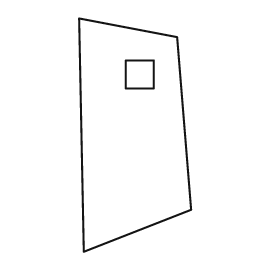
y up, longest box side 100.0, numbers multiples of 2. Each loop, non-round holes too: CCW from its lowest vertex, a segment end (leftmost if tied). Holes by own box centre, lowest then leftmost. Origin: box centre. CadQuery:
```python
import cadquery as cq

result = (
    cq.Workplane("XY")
    .moveTo(-22.0, -50.0)
    .lineTo(24.0, -32.0)
    .lineTo(18.0, 42.0)
    .lineTo(-24.0, 50.0)
    .close()
    .moveTo(-4.0, 20.0)
    .lineTo(8.0, 20.0)
    .lineTo(8.0, 32.0)
    .lineTo(-4.0, 32.0)
    .close()
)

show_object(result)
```